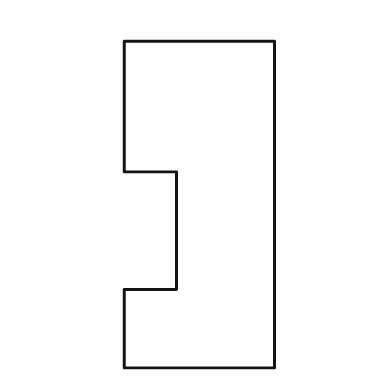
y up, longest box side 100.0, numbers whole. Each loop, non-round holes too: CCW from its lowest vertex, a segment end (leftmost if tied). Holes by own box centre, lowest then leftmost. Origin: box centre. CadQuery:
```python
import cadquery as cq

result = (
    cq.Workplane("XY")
    .moveTo(-23.0, -50.0)
    .lineTo(23.0, -50.0)
    .lineTo(23.0, 50.0)
    .lineTo(-23.0, 50.0)
    .lineTo(-23.0, 10.0)
    .lineTo(-7.0, 10.0)
    .lineTo(-7.0, -26.0)
    .lineTo(-23.0, -26.0)
    .close()
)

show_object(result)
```